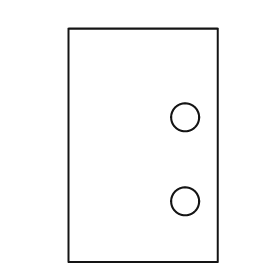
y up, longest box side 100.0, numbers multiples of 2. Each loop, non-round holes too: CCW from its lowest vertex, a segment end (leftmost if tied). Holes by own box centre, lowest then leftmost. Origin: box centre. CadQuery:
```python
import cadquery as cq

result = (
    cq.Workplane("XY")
    .moveTo(-32.0, -50.0)
    .lineTo(32.0, -50.0)
    .lineTo(32.0, 50.0)
    .lineTo(-32.0, 50.0)
    .close()
    .moveTo(18.0, -24.0)
    .circle(6.0)
    .moveTo(18.0, 12.0)
    .circle(6.0)
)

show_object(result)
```